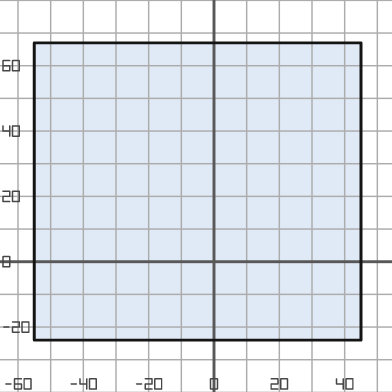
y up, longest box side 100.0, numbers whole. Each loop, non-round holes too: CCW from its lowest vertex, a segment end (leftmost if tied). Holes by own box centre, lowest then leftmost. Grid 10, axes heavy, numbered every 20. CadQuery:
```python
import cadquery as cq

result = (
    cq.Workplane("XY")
    .moveTo(-55.0, -24.0)
    .lineTo(45.0, -24.0)
    .lineTo(45.0, 67.0)
    .lineTo(-55.0, 67.0)
    .close()
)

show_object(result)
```